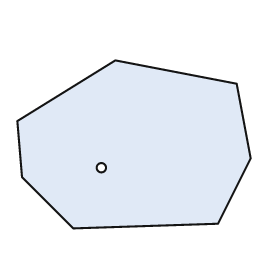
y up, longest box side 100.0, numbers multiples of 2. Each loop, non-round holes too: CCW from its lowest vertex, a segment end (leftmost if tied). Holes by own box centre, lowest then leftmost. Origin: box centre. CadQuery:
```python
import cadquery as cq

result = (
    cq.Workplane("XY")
    .moveTo(-26.0, -36.0)
    .lineTo(36.0, -34.0)
    .lineTo(50.0, -6.0)
    .lineTo(44.0, 26.0)
    .lineTo(-8.0, 36.0)
    .lineTo(-50.0, 10.0)
    .lineTo(-48.0, -14.0)
    .close()
    .moveTo(-14.0, -10.0)
    .circle(2.0)
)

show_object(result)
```